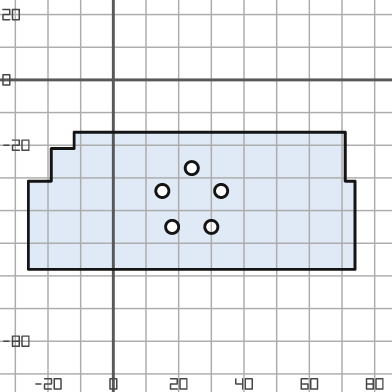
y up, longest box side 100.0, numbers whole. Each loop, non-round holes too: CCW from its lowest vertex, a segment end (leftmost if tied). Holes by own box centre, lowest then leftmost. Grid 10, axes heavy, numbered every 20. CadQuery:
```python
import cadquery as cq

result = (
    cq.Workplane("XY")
    .moveTo(-26.0, -58.0)
    .lineTo(74.0, -58.0)
    .lineTo(74.0, -31.0)
    .lineTo(71.0, -31.0)
    .lineTo(71.0, -16.0)
    .lineTo(-12.0, -16.0)
    .lineTo(-12.0, -21.0)
    .lineTo(-19.0, -21.0)
    .lineTo(-19.0, -31.0)
    .lineTo(-26.0, -31.0)
    .close()
    .moveTo(18.0, -45.0)
    .circle(2.0)
    .moveTo(30.0, -45.0)
    .circle(2.0)
    .moveTo(15.0, -34.0)
    .circle(2.0)
    .moveTo(33.0, -34.0)
    .circle(2.0)
    .moveTo(24.0, -27.0)
    .circle(2.0)
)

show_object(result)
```